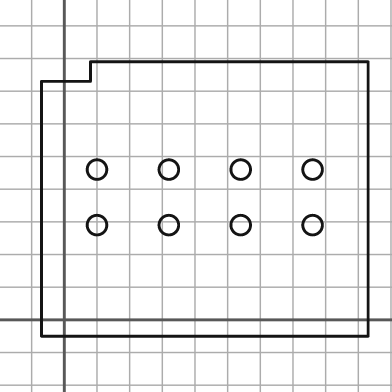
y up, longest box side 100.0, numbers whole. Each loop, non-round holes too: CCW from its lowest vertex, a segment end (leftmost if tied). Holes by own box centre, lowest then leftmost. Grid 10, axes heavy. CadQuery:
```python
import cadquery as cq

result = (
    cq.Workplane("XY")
    .moveTo(-7.0, -5.0)
    .lineTo(93.0, -5.0)
    .lineTo(93.0, 79.0)
    .lineTo(8.0, 79.0)
    .lineTo(8.0, 73.0)
    .lineTo(-7.0, 73.0)
    .close()
    .moveTo(10.0, 29.0)
    .circle(3.0)
    .moveTo(32.0, 29.0)
    .circle(3.0)
    .moveTo(54.0, 29.0)
    .circle(3.0)
    .moveTo(76.0, 29.0)
    .circle(3.0)
    .moveTo(10.0, 46.0)
    .circle(3.0)
    .moveTo(32.0, 46.0)
    .circle(3.0)
    .moveTo(54.0, 46.0)
    .circle(3.0)
    .moveTo(76.0, 46.0)
    .circle(3.0)
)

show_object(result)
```